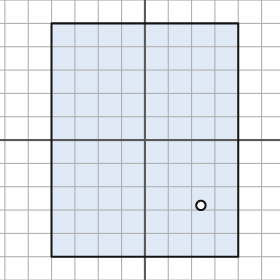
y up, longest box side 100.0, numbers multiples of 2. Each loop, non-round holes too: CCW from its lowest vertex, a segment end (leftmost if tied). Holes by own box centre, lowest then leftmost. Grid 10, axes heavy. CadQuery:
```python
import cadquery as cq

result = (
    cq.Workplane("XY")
    .moveTo(-40.0, -50.0)
    .lineTo(40.0, -50.0)
    .lineTo(40.0, 50.0)
    .lineTo(-40.0, 50.0)
    .close()
    .moveTo(24.0, -28.0)
    .circle(2.0)
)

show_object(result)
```